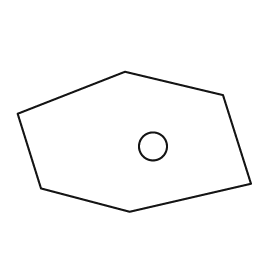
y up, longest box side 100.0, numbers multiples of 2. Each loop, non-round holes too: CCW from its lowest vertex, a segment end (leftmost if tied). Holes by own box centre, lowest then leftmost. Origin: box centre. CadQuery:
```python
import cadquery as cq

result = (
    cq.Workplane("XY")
    .moveTo(-2.0, -30.0)
    .lineTo(50.0, -18.0)
    .lineTo(38.0, 20.0)
    .lineTo(-4.0, 30.0)
    .lineTo(-50.0, 12.0)
    .lineTo(-40.0, -20.0)
    .close()
    .moveTo(8.0, -2.0)
    .circle(6.0)
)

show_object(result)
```